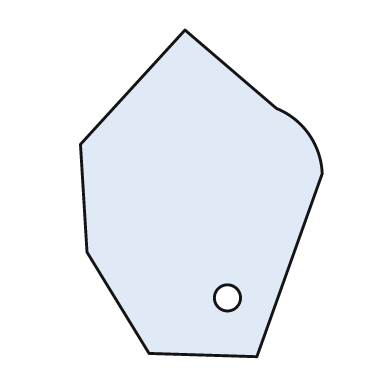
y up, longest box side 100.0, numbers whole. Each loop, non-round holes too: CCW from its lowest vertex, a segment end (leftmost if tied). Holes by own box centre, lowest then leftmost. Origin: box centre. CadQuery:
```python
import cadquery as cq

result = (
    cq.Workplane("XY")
    .moveTo(17.0, -50.0)
    .lineTo(37.0, 6.0)
    .threePointArc((33.0, 18.0), (23.0, 26.0))
    .lineTo(-5.0, 50.0)
    .lineTo(-37.0, 15.0)
    .lineTo(-35.0, -18.0)
    .lineTo(-16.0, -49.0)
    .close()
    .moveTo(8.0, -32.0)
    .circle(4.0)
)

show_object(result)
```